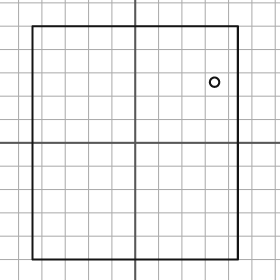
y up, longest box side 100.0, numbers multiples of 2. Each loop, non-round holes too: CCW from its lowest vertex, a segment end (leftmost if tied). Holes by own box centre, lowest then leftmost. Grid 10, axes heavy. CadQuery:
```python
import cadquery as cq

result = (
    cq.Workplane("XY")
    .moveTo(-44.0, -50.0)
    .lineTo(44.0, -50.0)
    .lineTo(44.0, 50.0)
    .lineTo(-44.0, 50.0)
    .close()
    .moveTo(34.0, 26.0)
    .circle(2.0)
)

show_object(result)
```